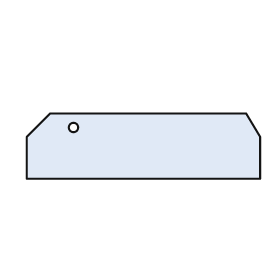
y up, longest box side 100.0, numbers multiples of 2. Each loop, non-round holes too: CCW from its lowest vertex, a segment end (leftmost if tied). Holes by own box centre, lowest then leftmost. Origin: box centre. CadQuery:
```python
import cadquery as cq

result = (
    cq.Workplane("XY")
    .moveTo(-50.0, -14.0)
    .lineTo(50.0, -14.0)
    .lineTo(50.0, 4.0)
    .lineTo(44.0, 14.0)
    .lineTo(-40.0, 14.0)
    .lineTo(-50.0, 4.0)
    .close()
    .moveTo(-30.0, 8.0)
    .circle(2.0)
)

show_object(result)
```